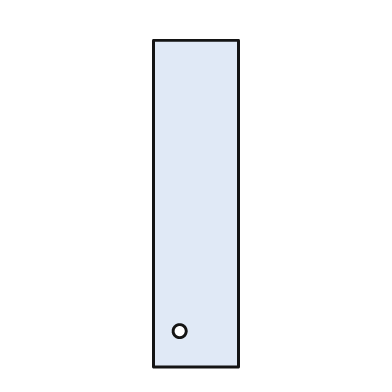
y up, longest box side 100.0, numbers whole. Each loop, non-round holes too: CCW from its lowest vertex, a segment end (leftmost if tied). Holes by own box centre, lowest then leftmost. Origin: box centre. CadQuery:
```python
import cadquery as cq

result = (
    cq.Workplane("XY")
    .moveTo(-13.0, -50.0)
    .lineTo(13.0, -50.0)
    .lineTo(13.0, 50.0)
    .lineTo(-13.0, 50.0)
    .close()
    .moveTo(-5.0, -39.0)
    .circle(2.0)
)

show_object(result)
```